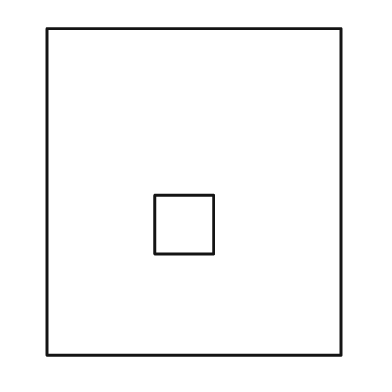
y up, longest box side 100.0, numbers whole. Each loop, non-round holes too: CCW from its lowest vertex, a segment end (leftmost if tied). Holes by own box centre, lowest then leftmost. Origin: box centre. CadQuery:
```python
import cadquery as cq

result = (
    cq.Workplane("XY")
    .moveTo(-45.0, -50.0)
    .lineTo(45.0, -50.0)
    .lineTo(45.0, 50.0)
    .lineTo(-45.0, 50.0)
    .close()
    .moveTo(-12.0, -19.0)
    .lineTo(6.0, -19.0)
    .lineTo(6.0, -1.0)
    .lineTo(-12.0, -1.0)
    .close()
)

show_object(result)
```